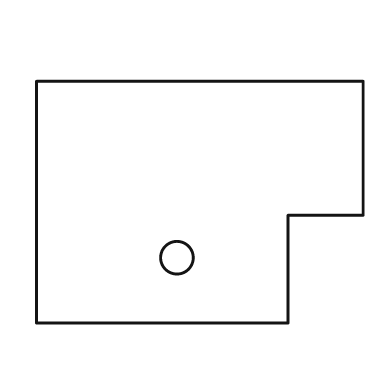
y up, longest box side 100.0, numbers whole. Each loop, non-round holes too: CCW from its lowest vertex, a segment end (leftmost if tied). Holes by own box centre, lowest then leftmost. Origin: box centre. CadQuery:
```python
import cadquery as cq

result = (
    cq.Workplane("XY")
    .moveTo(-50.0, -37.0)
    .lineTo(27.0, -37.0)
    .lineTo(27.0, -4.0)
    .lineTo(50.0, -4.0)
    .lineTo(50.0, 37.0)
    .lineTo(-50.0, 37.0)
    .close()
    .moveTo(-7.0, -17.0)
    .circle(5.0)
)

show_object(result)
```